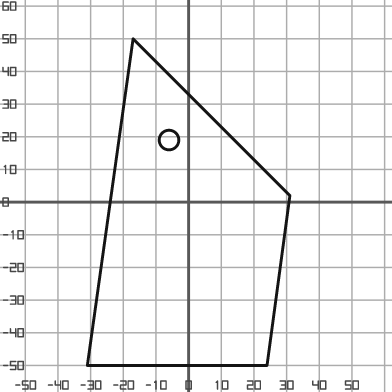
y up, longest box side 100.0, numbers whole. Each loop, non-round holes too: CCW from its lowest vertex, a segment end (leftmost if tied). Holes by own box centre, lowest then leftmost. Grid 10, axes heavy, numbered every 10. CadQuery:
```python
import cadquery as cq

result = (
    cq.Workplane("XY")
    .moveTo(-31.0, -50.0)
    .lineTo(24.0, -50.0)
    .lineTo(31.0, 2.0)
    .lineTo(-17.0, 50.0)
    .close()
    .moveTo(-6.0, 19.0)
    .circle(3.0)
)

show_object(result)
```